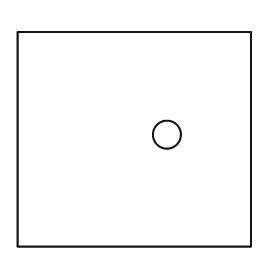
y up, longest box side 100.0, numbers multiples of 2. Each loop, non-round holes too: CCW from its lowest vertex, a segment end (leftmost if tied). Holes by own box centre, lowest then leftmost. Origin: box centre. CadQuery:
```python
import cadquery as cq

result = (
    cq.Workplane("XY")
    .moveTo(-50.0, -46.0)
    .lineTo(50.0, -46.0)
    .lineTo(50.0, 46.0)
    .lineTo(-50.0, 46.0)
    .close()
    .moveTo(14.0, 2.0)
    .circle(6.0)
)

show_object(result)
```